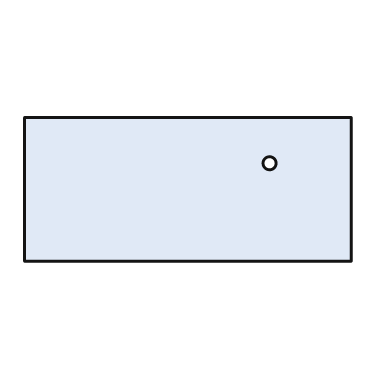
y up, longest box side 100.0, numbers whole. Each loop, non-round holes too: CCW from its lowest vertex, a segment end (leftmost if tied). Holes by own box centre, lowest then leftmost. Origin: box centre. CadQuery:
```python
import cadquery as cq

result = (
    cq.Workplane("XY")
    .moveTo(-50.0, -22.0)
    .lineTo(50.0, -22.0)
    .lineTo(50.0, 22.0)
    .lineTo(-50.0, 22.0)
    .close()
    .moveTo(25.0, 8.0)
    .circle(2.0)
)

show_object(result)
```